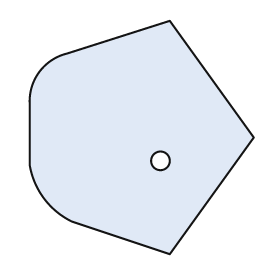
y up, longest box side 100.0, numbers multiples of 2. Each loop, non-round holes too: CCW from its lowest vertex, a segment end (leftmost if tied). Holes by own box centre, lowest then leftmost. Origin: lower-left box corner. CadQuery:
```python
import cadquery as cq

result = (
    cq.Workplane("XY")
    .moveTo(60.0, 0.0)
    .lineTo(96.0, 50.0)
    .lineTo(60.0, 100.0)
    .lineTo(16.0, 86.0)
    .threePointArc((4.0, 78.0), (0.0, 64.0))
    .lineTo(0.0, 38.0)
    .threePointArc((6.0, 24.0), (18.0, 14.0))
    .close()
    .moveTo(56.0, 40.0)
    .circle(4.0)
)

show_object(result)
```